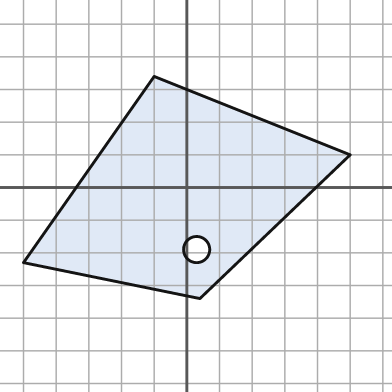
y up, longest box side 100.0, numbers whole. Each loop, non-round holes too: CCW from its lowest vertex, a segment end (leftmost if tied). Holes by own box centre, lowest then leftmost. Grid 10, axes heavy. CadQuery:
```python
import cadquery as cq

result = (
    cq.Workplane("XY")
    .moveTo(4.0, -34.0)
    .lineTo(50.0, 10.0)
    .lineTo(-10.0, 34.0)
    .lineTo(-50.0, -23.0)
    .close()
    .moveTo(3.0, -19.0)
    .circle(4.0)
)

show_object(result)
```